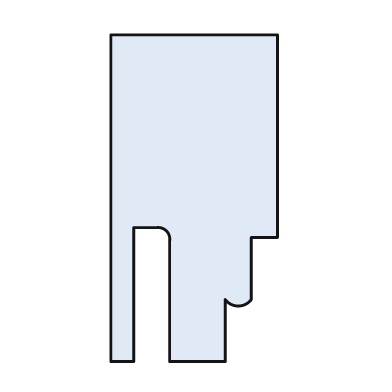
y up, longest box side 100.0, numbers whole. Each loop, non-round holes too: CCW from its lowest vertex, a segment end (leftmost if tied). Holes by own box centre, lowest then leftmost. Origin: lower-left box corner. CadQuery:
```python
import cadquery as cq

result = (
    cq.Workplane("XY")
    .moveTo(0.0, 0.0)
    .lineTo(7.0, 0.0)
    .lineTo(7.0, 41.0)
    .lineTo(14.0, 41.0)
    .threePointArc((17.0, 40.0), (18.0, 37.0))
    .lineTo(18.0, 0.0)
    .lineTo(35.0, 0.0)
    .lineTo(35.0, 19.0)
    .threePointArc((39.0, 17.0), (43.0, 19.0))
    .lineTo(43.0, 38.0)
    .lineTo(51.0, 38.0)
    .lineTo(51.0, 100.0)
    .lineTo(0.0, 100.0)
    .close()
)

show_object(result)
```